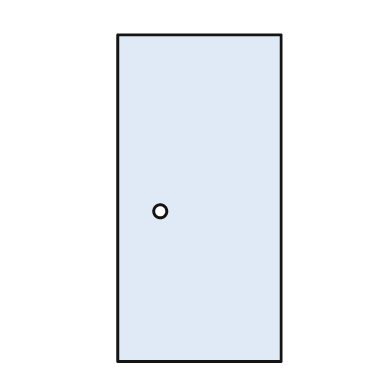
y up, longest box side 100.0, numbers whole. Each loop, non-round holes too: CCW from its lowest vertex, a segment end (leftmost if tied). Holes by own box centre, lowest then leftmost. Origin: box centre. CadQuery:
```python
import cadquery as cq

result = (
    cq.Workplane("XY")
    .moveTo(-25.0, -50.0)
    .lineTo(25.0, -50.0)
    .lineTo(25.0, 50.0)
    .lineTo(-25.0, 50.0)
    .close()
    .moveTo(-12.0, -4.0)
    .circle(2.0)
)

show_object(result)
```